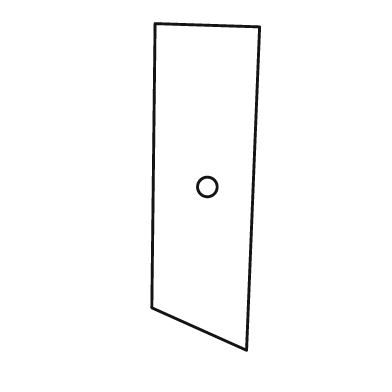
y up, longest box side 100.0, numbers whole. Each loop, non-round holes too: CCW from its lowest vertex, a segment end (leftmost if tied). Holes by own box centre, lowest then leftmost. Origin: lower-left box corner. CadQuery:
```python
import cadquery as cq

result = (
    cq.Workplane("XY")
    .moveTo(29.0, 0.0)
    .lineTo(33.0, 99.0)
    .lineTo(1.0, 100.0)
    .lineTo(0.0, 13.0)
    .close()
    .moveTo(17.0, 50.0)
    .circle(3.0)
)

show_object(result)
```